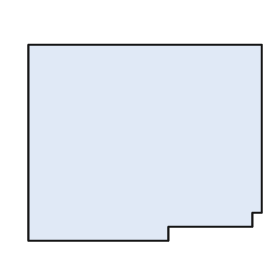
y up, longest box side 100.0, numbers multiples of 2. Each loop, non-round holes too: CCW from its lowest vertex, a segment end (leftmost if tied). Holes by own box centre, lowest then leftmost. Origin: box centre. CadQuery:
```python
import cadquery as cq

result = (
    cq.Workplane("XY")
    .moveTo(-50.0, -42.0)
    .lineTo(10.0, -42.0)
    .lineTo(10.0, -36.0)
    .lineTo(46.0, -36.0)
    .lineTo(46.0, -30.0)
    .lineTo(50.0, -30.0)
    .lineTo(50.0, 42.0)
    .lineTo(-50.0, 42.0)
    .close()
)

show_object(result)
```